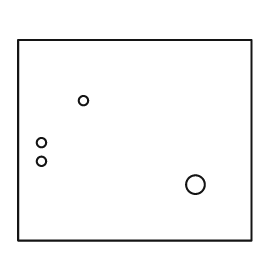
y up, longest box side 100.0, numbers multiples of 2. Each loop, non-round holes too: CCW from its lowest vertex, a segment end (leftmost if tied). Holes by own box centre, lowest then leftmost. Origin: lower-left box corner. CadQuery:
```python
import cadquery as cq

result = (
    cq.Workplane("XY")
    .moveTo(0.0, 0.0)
    .lineTo(100.0, 0.0)
    .lineTo(100.0, 86.0)
    .lineTo(0.0, 86.0)
    .close()
    .moveTo(76.0, 24.0)
    .circle(4.0)
    .moveTo(10.0, 34.0)
    .circle(2.0)
    .moveTo(10.0, 42.0)
    .circle(2.0)
    .moveTo(28.0, 60.0)
    .circle(2.0)
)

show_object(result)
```